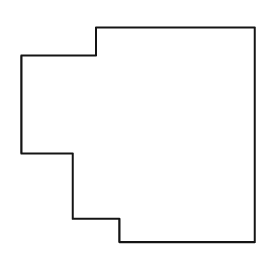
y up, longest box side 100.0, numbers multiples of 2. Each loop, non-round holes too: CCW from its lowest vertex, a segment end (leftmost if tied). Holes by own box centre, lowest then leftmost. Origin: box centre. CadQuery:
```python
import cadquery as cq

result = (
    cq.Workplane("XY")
    .moveTo(-8.0, -46.0)
    .lineTo(50.0, -46.0)
    .lineTo(50.0, 46.0)
    .lineTo(-18.0, 46.0)
    .lineTo(-18.0, 34.0)
    .lineTo(-50.0, 34.0)
    .lineTo(-50.0, -8.0)
    .lineTo(-28.0, -8.0)
    .lineTo(-28.0, -36.0)
    .lineTo(-8.0, -36.0)
    .close()
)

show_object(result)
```